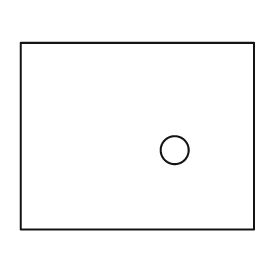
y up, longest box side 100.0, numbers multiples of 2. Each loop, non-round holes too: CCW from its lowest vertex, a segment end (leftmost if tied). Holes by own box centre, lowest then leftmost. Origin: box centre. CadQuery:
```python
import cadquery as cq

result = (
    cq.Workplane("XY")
    .moveTo(-50.0, -40.0)
    .lineTo(50.0, -40.0)
    .lineTo(50.0, 40.0)
    .lineTo(-50.0, 40.0)
    .close()
    .moveTo(16.0, -6.0)
    .circle(6.0)
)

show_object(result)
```